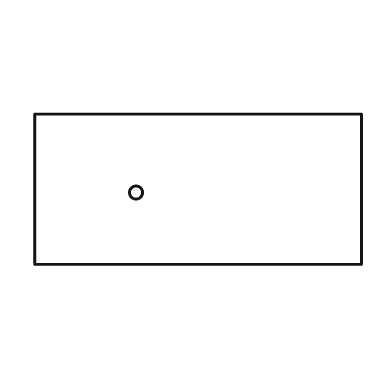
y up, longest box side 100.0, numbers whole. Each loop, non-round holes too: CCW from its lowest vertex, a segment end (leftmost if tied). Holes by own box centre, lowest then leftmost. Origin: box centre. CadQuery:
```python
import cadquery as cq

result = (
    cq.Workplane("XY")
    .moveTo(-50.0, -23.0)
    .lineTo(50.0, -23.0)
    .lineTo(50.0, 23.0)
    .lineTo(-50.0, 23.0)
    .close()
    .moveTo(-19.0, -1.0)
    .circle(2.0)
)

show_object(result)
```